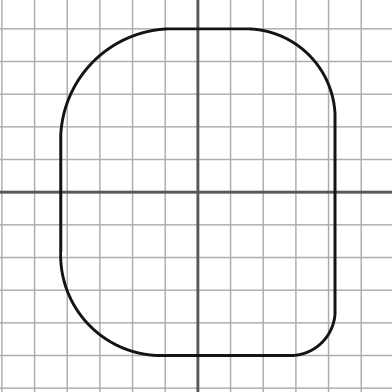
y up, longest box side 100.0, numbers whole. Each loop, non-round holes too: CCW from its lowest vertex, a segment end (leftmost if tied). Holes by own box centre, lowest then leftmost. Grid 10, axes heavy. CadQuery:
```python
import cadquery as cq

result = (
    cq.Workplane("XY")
    .moveTo(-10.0, -50.0)
    .lineTo(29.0, -50.0)
    .threePointArc((38.0, -46.0), (42.0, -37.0))
    .lineTo(42.0, 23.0)
    .threePointArc((34.0, 42.0), (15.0, 50.0))
    .lineTo(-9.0, 50.0)
    .threePointArc((-32.0, 40.0), (-42.0, 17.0))
    .lineTo(-42.0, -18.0)
    .threePointArc((-33.0, -41.0), (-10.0, -50.0))
    .close()
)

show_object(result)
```